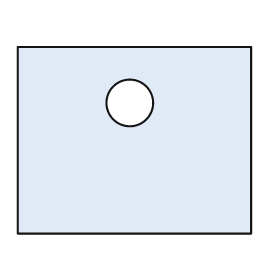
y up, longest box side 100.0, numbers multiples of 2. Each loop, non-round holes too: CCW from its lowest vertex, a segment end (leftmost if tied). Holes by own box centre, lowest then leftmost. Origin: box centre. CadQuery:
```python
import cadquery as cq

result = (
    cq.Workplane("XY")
    .moveTo(-50.0, -40.0)
    .lineTo(50.0, -40.0)
    .lineTo(50.0, 40.0)
    .lineTo(-50.0, 40.0)
    .close()
    .moveTo(-2.0, 16.0)
    .circle(10.0)
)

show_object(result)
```